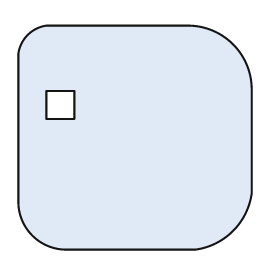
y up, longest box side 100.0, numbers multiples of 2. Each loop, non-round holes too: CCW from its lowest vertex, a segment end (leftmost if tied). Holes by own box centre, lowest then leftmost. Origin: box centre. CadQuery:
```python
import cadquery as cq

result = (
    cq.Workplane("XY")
    .moveTo(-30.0, -48.0)
    .lineTo(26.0, -48.0)
    .threePointArc((42.0, -40.0), (50.0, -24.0))
    .lineTo(50.0, 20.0)
    .threePointArc((42.0, 40.0), (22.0, 48.0))
    .lineTo(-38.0, 48.0)
    .threePointArc((-46.0, 44.0), (-50.0, 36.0))
    .lineTo(-50.0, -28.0)
    .threePointArc((-44.0, -42.0), (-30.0, -48.0))
    .close()
    .moveTo(-38.0, 8.0)
    .lineTo(-26.0, 8.0)
    .lineTo(-26.0, 20.0)
    .lineTo(-38.0, 20.0)
    .close()
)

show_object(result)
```